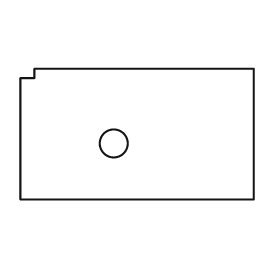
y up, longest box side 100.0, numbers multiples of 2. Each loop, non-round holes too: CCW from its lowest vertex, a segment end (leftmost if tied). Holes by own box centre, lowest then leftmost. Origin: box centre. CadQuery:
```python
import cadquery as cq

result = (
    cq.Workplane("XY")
    .moveTo(-50.0, -28.0)
    .lineTo(50.0, -28.0)
    .lineTo(50.0, 28.0)
    .lineTo(-44.0, 28.0)
    .lineTo(-44.0, 24.0)
    .lineTo(-50.0, 24.0)
    .close()
    .moveTo(-10.0, -4.0)
    .circle(6.0)
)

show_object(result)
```